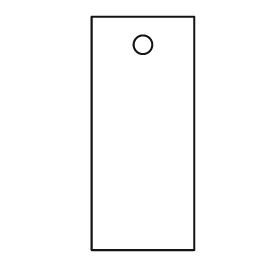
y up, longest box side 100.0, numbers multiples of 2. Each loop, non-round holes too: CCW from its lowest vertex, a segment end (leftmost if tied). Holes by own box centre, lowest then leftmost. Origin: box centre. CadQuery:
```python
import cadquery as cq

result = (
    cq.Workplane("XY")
    .moveTo(-22.0, -50.0)
    .lineTo(22.0, -50.0)
    .lineTo(22.0, 50.0)
    .lineTo(-22.0, 50.0)
    .close()
    .moveTo(0.0, 38.0)
    .circle(4.0)
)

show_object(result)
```